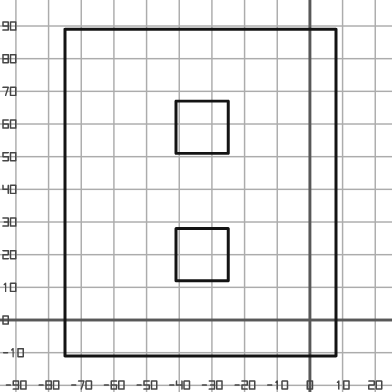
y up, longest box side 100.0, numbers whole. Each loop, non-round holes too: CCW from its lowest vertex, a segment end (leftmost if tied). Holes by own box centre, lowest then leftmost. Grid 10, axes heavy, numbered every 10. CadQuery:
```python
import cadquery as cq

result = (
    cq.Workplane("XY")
    .moveTo(-75.0, -11.0)
    .lineTo(8.0, -11.0)
    .lineTo(8.0, 89.0)
    .lineTo(-75.0, 89.0)
    .close()
    .moveTo(-41.0, 12.0)
    .lineTo(-25.0, 12.0)
    .lineTo(-25.0, 28.0)
    .lineTo(-41.0, 28.0)
    .close()
    .moveTo(-41.0, 51.0)
    .lineTo(-25.0, 51.0)
    .lineTo(-25.0, 67.0)
    .lineTo(-41.0, 67.0)
    .close()
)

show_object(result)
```